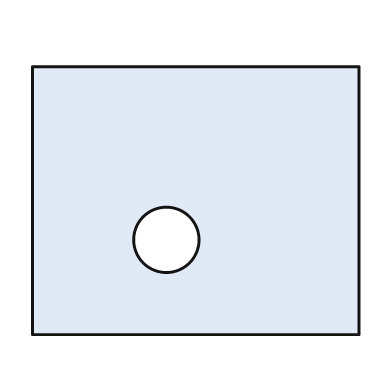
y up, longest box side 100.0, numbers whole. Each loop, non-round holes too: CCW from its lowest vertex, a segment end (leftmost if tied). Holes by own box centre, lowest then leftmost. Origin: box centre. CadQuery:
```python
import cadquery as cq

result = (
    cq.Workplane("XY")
    .moveTo(-50.0, -41.0)
    .lineTo(50.0, -41.0)
    .lineTo(50.0, 41.0)
    .lineTo(-50.0, 41.0)
    .close()
    .moveTo(-9.0, -12.0)
    .circle(10.0)
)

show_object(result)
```